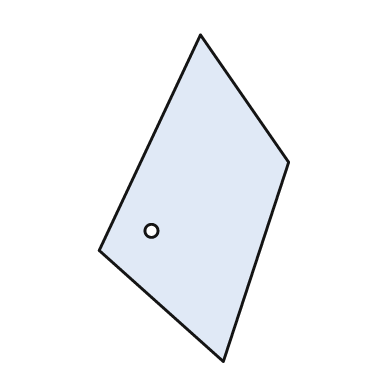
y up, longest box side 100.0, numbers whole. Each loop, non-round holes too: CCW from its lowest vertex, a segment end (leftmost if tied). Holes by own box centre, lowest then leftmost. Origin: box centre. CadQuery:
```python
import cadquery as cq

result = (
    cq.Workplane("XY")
    .moveTo(9.0, -50.0)
    .lineTo(29.0, 11.0)
    .lineTo(2.0, 50.0)
    .lineTo(-29.0, -16.0)
    .close()
    .moveTo(-13.0, -10.0)
    .circle(2.0)
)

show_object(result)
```